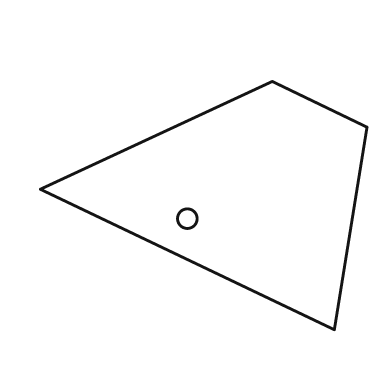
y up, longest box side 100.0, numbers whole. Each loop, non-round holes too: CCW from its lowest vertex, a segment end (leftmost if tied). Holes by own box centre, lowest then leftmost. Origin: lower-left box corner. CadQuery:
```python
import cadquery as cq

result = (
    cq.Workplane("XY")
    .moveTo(90.0, 0.0)
    .lineTo(100.0, 62.0)
    .lineTo(71.0, 76.0)
    .lineTo(0.0, 43.0)
    .close()
    .moveTo(45.0, 34.0)
    .circle(3.0)
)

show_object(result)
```